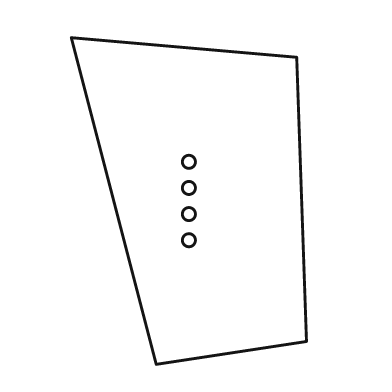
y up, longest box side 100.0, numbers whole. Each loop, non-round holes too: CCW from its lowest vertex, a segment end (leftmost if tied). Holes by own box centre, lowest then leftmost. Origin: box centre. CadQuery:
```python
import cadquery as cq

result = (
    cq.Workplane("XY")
    .moveTo(-10.0, -50.0)
    .lineTo(36.0, -43.0)
    .lineTo(33.0, 44.0)
    .lineTo(-36.0, 50.0)
    .close()
    .moveTo(0.0, -12.0)
    .circle(2.0)
    .moveTo(0.0, -4.0)
    .circle(2.0)
    .moveTo(0.0, 4.0)
    .circle(2.0)
    .moveTo(0.0, 12.0)
    .circle(2.0)
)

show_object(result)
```